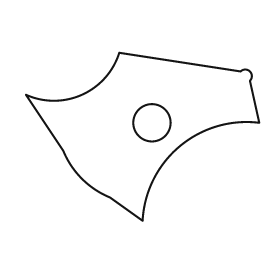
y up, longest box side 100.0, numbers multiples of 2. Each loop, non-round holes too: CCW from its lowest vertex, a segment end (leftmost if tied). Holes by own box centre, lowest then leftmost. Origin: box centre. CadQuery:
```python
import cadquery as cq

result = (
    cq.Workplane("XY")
    .moveTo(0.0, -36.0)
    .threePointArc((16.0, -4.0), (50.0, 6.0))
    .lineTo(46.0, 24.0)
    .threePointArc((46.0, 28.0), (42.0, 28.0))
    .lineTo(-10.0, 36.0)
    .threePointArc((-26.0, 18.0), (-50.0, 18.0))
    .lineTo(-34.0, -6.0)
    .threePointArc((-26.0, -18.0), (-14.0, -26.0))
    .close()
    .moveTo(4.0, 6.0)
    .circle(8.0)
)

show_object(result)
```